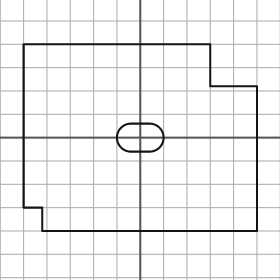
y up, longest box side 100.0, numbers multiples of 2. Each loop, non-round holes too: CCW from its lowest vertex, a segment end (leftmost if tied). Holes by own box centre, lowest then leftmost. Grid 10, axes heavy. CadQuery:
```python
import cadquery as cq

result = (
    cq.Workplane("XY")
    .moveTo(-42.0, -40.0)
    .lineTo(50.0, -40.0)
    .lineTo(50.0, 22.0)
    .lineTo(30.0, 22.0)
    .lineTo(30.0, 40.0)
    .lineTo(-50.0, 40.0)
    .lineTo(-50.0, -30.0)
    .lineTo(-42.0, -30.0)
    .close()
    .moveTo(-4.0, -6.0)
    .lineTo(4.0, -6.0)
    .threePointArc((10.0, 0.0), (4.0, 6.0))
    .lineTo(-4.0, 6.0)
    .threePointArc((-10.0, 0.0), (-4.0, -6.0))
    .close()
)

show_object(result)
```